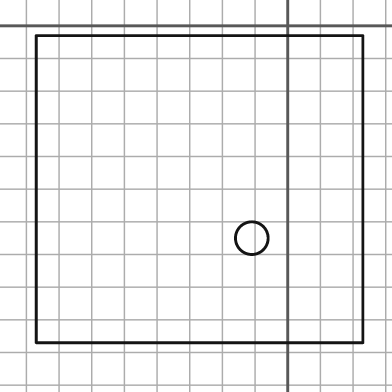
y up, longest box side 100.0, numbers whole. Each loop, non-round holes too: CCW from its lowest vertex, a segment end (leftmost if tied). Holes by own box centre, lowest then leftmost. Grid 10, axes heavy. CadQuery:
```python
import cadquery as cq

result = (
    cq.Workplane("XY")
    .moveTo(-77.0, -97.0)
    .lineTo(23.0, -97.0)
    .lineTo(23.0, -3.0)
    .lineTo(-77.0, -3.0)
    .close()
    .moveTo(-11.0, -65.0)
    .circle(5.0)
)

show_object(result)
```